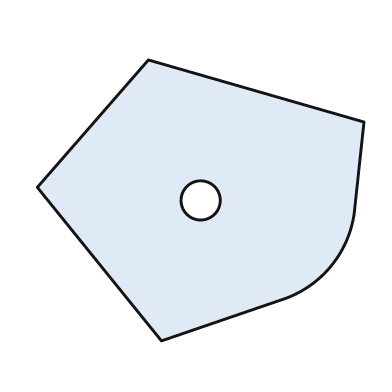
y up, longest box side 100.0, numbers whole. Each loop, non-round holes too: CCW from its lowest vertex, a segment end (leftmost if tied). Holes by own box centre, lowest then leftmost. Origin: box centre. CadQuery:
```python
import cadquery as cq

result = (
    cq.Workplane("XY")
    .moveTo(-12.0, -43.0)
    .lineTo(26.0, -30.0)
    .threePointArc((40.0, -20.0), (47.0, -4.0))
    .lineTo(50.0, 24.0)
    .lineTo(-16.0, 43.0)
    .lineTo(-50.0, 4.0)
    .close()
    .moveTo(0.0, 0.0)
    .circle(6.0)
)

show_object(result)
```